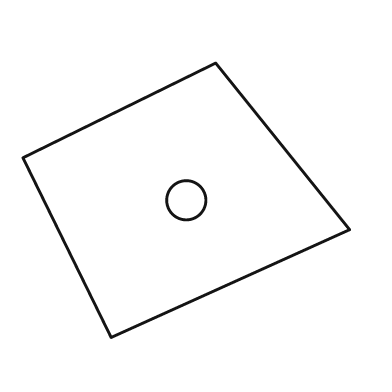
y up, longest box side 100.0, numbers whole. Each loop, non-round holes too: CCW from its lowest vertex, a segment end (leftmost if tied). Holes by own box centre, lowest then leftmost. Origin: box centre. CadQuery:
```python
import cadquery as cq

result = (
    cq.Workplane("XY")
    .moveTo(-23.0, -42.0)
    .lineTo(50.0, -9.0)
    .lineTo(9.0, 42.0)
    .lineTo(-50.0, 13.0)
    .close()
    .moveTo(0.0, 0.0)
    .circle(6.0)
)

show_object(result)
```